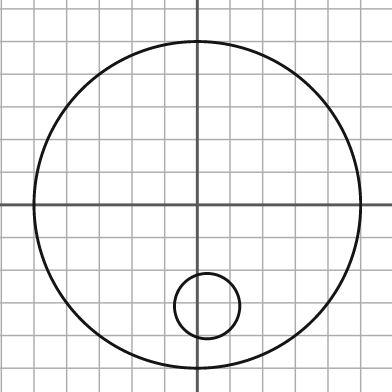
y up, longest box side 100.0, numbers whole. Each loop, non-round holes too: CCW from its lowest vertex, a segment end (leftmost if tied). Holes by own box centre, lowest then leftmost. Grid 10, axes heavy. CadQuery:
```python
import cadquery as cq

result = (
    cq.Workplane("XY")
    .moveTo(0.0, 0.0)
    .circle(50.0)
    .moveTo(3.0, -31.0)
    .circle(10.0)
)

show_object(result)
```